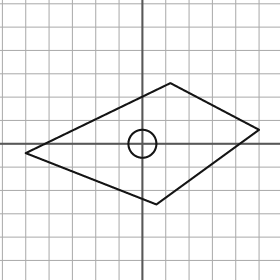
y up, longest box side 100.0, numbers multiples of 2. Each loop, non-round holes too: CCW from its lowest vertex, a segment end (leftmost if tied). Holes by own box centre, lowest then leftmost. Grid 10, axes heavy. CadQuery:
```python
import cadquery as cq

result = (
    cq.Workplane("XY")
    .moveTo(6.0, -26.0)
    .lineTo(50.0, 6.0)
    .lineTo(12.0, 26.0)
    .lineTo(-50.0, -4.0)
    .close()
    .moveTo(0.0, 0.0)
    .circle(6.0)
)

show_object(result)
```